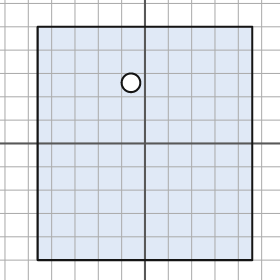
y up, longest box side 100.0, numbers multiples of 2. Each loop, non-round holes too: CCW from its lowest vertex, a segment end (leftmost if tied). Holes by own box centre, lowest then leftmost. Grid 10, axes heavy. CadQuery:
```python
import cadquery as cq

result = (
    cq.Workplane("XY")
    .moveTo(-46.0, -50.0)
    .lineTo(46.0, -50.0)
    .lineTo(46.0, 50.0)
    .lineTo(-46.0, 50.0)
    .close()
    .moveTo(-6.0, 26.0)
    .circle(4.0)
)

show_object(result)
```